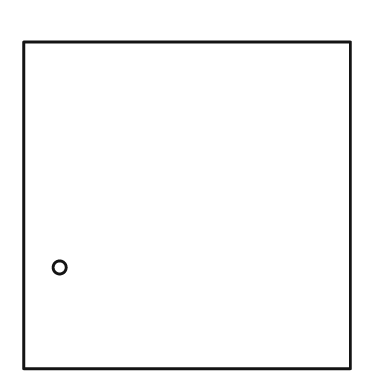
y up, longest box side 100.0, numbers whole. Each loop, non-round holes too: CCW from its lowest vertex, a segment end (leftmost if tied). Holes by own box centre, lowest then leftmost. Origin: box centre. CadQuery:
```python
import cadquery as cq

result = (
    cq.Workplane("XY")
    .moveTo(-50.0, -50.0)
    .lineTo(50.0, -50.0)
    .lineTo(50.0, 50.0)
    .lineTo(-50.0, 50.0)
    .close()
    .moveTo(-39.0, -19.0)
    .circle(2.0)
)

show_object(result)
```